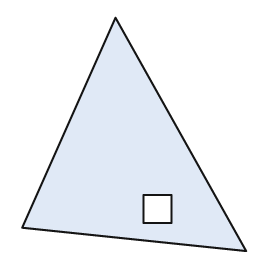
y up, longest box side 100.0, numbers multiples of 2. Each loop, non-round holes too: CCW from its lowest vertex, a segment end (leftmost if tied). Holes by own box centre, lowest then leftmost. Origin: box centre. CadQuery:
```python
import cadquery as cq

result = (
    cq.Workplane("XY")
    .moveTo(48.0, -50.0)
    .lineTo(-8.0, 50.0)
    .lineTo(-48.0, -40.0)
    .close()
    .moveTo(4.0, -38.0)
    .lineTo(16.0, -38.0)
    .lineTo(16.0, -26.0)
    .lineTo(4.0, -26.0)
    .close()
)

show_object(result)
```